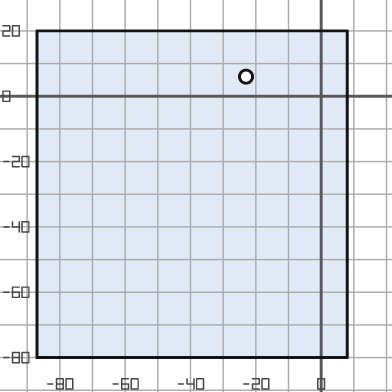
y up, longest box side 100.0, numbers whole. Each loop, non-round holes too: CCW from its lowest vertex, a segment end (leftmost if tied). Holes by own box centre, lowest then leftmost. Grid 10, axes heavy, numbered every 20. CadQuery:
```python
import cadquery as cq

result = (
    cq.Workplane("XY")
    .moveTo(-87.0, -80.0)
    .lineTo(8.0, -80.0)
    .lineTo(8.0, 20.0)
    .lineTo(-87.0, 20.0)
    .close()
    .moveTo(-23.0, 6.0)
    .circle(2.0)
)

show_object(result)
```